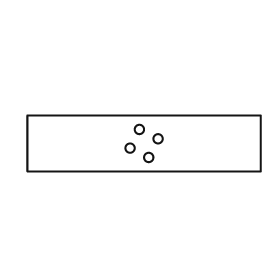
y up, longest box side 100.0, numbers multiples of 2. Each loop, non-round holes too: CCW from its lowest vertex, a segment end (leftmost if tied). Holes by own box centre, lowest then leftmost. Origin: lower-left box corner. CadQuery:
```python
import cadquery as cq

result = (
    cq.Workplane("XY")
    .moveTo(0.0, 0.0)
    .lineTo(100.0, 0.0)
    .lineTo(100.0, 24.0)
    .lineTo(0.0, 24.0)
    .close()
    .moveTo(52.0, 6.0)
    .circle(2.0)
    .moveTo(44.0, 10.0)
    .circle(2.0)
    .moveTo(56.0, 14.0)
    .circle(2.0)
    .moveTo(48.0, 18.0)
    .circle(2.0)
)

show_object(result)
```